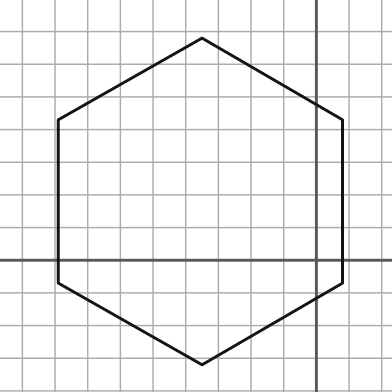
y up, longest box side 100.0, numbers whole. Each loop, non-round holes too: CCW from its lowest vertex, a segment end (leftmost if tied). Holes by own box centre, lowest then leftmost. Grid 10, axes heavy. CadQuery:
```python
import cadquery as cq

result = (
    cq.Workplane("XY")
    .moveTo(-35.0, -32.0)
    .lineTo(8.0, -7.0)
    .lineTo(8.0, 43.0)
    .lineTo(-35.0, 68.0)
    .lineTo(-79.0, 43.0)
    .lineTo(-79.0, -7.0)
    .close()
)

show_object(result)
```